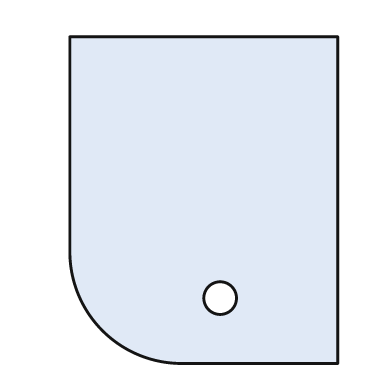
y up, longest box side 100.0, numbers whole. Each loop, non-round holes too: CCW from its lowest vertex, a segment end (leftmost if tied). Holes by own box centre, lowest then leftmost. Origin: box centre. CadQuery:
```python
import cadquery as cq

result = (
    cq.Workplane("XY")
    .moveTo(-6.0, -50.0)
    .lineTo(41.0, -50.0)
    .lineTo(41.0, 50.0)
    .lineTo(-41.0, 50.0)
    .lineTo(-41.0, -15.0)
    .threePointArc((-31.0, -40.0), (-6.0, -50.0))
    .close()
    .moveTo(5.0, -30.0)
    .circle(5.0)
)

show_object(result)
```